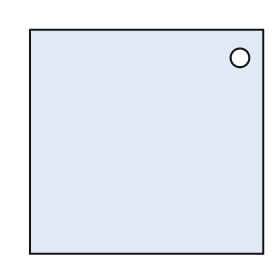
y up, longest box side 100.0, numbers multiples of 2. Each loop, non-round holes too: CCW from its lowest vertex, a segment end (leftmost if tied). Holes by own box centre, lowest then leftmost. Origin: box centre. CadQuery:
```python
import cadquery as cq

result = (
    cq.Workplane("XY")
    .moveTo(-50.0, -48.0)
    .lineTo(50.0, -48.0)
    .lineTo(50.0, 48.0)
    .lineTo(-50.0, 48.0)
    .close()
    .moveTo(40.0, 36.0)
    .circle(4.0)
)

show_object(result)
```